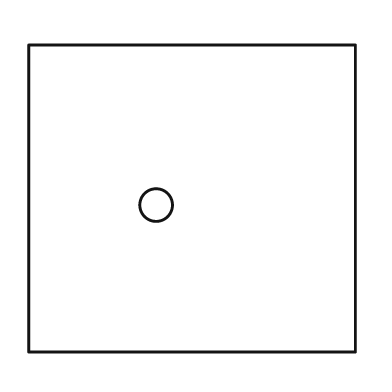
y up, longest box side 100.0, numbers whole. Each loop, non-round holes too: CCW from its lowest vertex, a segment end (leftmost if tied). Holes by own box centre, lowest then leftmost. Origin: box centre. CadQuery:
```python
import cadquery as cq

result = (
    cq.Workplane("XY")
    .moveTo(-50.0, -47.0)
    .lineTo(50.0, -47.0)
    .lineTo(50.0, 47.0)
    .lineTo(-50.0, 47.0)
    .close()
    .moveTo(-11.0, -2.0)
    .circle(5.0)
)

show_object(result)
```